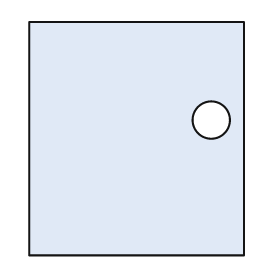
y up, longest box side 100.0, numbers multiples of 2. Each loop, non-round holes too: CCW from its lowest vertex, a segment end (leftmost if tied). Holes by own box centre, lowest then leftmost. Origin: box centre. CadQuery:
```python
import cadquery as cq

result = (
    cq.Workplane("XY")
    .moveTo(-46.0, -50.0)
    .lineTo(46.0, -50.0)
    .lineTo(46.0, 50.0)
    .lineTo(-46.0, 50.0)
    .close()
    .moveTo(32.0, 8.0)
    .circle(8.0)
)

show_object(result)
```